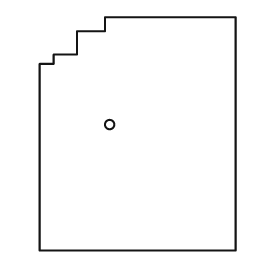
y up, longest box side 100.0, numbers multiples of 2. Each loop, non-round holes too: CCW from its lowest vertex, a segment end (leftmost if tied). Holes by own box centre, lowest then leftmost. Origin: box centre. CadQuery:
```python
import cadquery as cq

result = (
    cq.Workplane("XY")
    .moveTo(-42.0, -50.0)
    .lineTo(42.0, -50.0)
    .lineTo(42.0, 50.0)
    .lineTo(-14.0, 50.0)
    .lineTo(-14.0, 44.0)
    .lineTo(-26.0, 44.0)
    .lineTo(-26.0, 34.0)
    .lineTo(-36.0, 34.0)
    .lineTo(-36.0, 30.0)
    .lineTo(-42.0, 30.0)
    .close()
    .moveTo(-12.0, 4.0)
    .circle(2.0)
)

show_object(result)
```